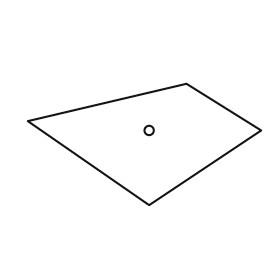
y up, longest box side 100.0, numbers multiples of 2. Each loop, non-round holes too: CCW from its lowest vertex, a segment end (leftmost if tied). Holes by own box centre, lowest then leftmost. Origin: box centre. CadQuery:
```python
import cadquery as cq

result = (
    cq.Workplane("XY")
    .moveTo(2.0, -26.0)
    .lineTo(50.0, 6.0)
    .lineTo(18.0, 26.0)
    .lineTo(-50.0, 10.0)
    .close()
    .moveTo(2.0, 6.0)
    .circle(2.0)
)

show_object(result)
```